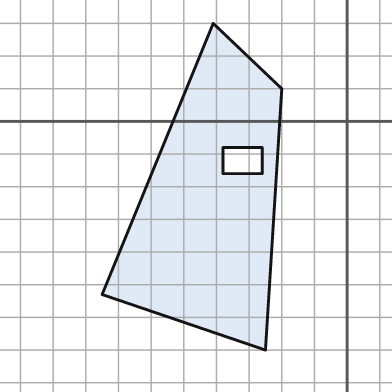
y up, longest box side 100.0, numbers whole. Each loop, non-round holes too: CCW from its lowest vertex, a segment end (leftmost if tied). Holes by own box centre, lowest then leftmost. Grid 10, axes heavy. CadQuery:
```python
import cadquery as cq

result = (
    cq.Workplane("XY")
    .moveTo(-25.0, -70.0)
    .lineTo(-20.0, 10.0)
    .lineTo(-41.0, 30.0)
    .lineTo(-75.0, -53.0)
    .close()
    .moveTo(-38.0, -16.0)
    .lineTo(-26.0, -16.0)
    .lineTo(-26.0, -8.0)
    .lineTo(-38.0, -8.0)
    .close()
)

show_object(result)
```